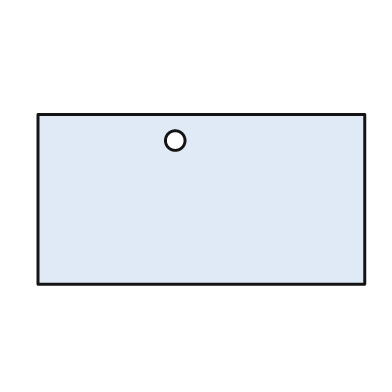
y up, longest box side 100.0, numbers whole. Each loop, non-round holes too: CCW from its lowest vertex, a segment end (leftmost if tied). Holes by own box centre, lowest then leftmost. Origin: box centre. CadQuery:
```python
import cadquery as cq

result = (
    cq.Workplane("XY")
    .moveTo(-50.0, -26.0)
    .lineTo(50.0, -26.0)
    .lineTo(50.0, 26.0)
    .lineTo(-50.0, 26.0)
    .close()
    .moveTo(-8.0, 18.0)
    .circle(3.0)
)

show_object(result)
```